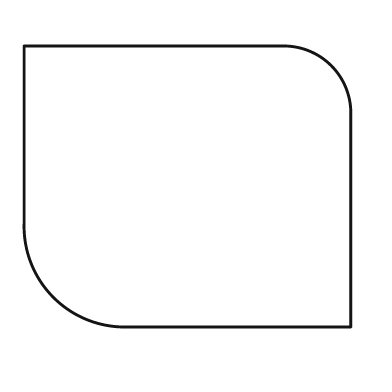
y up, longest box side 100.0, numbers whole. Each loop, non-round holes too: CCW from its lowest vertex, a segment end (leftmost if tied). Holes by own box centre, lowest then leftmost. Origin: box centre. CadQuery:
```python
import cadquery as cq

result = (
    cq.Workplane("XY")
    .moveTo(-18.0, -43.0)
    .lineTo(50.0, -43.0)
    .lineTo(50.0, 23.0)
    .threePointArc((44.0, 37.0), (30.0, 43.0))
    .lineTo(-50.0, 43.0)
    .lineTo(-50.0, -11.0)
    .threePointArc((-41.0, -34.0), (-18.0, -43.0))
    .close()
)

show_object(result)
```